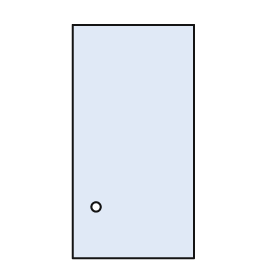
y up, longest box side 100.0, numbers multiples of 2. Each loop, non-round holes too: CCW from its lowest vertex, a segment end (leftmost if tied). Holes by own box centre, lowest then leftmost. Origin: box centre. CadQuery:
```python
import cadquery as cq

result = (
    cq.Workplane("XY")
    .moveTo(-26.0, -50.0)
    .lineTo(26.0, -50.0)
    .lineTo(26.0, 50.0)
    .lineTo(-26.0, 50.0)
    .close()
    .moveTo(-16.0, -28.0)
    .circle(2.0)
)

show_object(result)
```